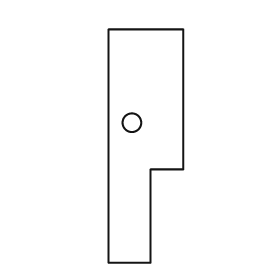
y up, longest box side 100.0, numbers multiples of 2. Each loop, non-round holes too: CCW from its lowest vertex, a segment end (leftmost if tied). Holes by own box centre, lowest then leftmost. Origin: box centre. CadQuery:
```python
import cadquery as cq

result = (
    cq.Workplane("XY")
    .moveTo(-16.0, -50.0)
    .lineTo(2.0, -50.0)
    .lineTo(2.0, -10.0)
    .lineTo(16.0, -10.0)
    .lineTo(16.0, 50.0)
    .lineTo(-16.0, 50.0)
    .close()
    .moveTo(-6.0, 10.0)
    .circle(4.0)
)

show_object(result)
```